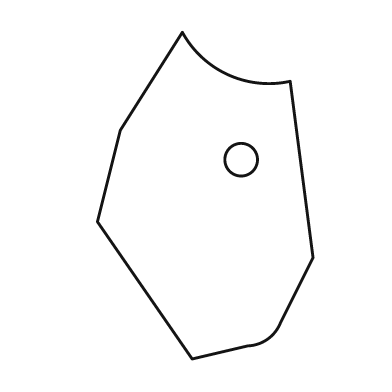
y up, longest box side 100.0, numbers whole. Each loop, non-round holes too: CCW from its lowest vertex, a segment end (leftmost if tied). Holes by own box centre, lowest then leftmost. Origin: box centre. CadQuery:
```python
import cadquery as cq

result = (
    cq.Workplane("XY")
    .moveTo(-4.0, -50.0)
    .lineTo(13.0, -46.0)
    .threePointArc((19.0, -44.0), (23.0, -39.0))
    .lineTo(33.0, -19.0)
    .lineTo(26.0, 35.0)
    .threePointArc((7.0, 37.0), (-7.0, 50.0))
    .lineTo(-26.0, 20.0)
    .lineTo(-33.0, -8.0)
    .close()
    .moveTo(11.0, 11.0)
    .circle(5.0)
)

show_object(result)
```